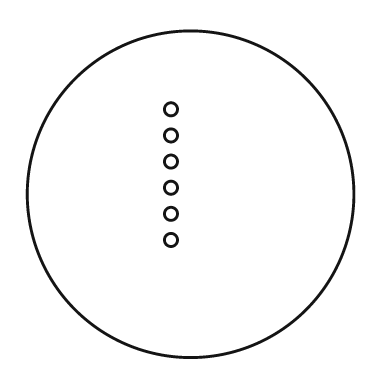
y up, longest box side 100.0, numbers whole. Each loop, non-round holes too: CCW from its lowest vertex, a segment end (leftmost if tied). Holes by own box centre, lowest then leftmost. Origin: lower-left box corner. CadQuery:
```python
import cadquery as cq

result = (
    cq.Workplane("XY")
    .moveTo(50.0, 50.0)
    .circle(50.0)
    .moveTo(44.0, 36.0)
    .circle(2.0)
    .moveTo(44.0, 44.0)
    .circle(2.0)
    .moveTo(44.0, 52.0)
    .circle(2.0)
    .moveTo(44.0, 60.0)
    .circle(2.0)
    .moveTo(44.0, 68.0)
    .circle(2.0)
    .moveTo(44.0, 76.0)
    .circle(2.0)
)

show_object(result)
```